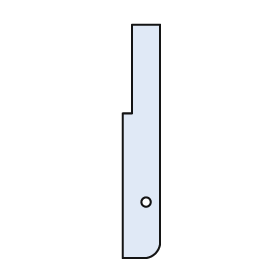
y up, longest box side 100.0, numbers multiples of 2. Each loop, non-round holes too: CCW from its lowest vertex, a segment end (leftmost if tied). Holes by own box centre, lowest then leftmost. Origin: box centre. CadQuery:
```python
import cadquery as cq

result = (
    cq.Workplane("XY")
    .moveTo(-8.0, -50.0)
    .lineTo(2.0, -50.0)
    .threePointArc((6.0, -48.0), (8.0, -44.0))
    .lineTo(8.0, 50.0)
    .lineTo(-4.0, 50.0)
    .lineTo(-4.0, 12.0)
    .lineTo(-8.0, 12.0)
    .close()
    .moveTo(2.0, -26.0)
    .circle(2.0)
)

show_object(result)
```